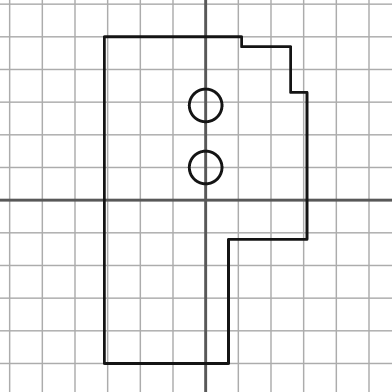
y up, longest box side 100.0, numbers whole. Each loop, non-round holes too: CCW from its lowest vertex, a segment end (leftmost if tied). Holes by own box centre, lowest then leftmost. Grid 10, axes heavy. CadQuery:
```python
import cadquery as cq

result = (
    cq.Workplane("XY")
    .moveTo(-31.0, -50.0)
    .lineTo(7.0, -50.0)
    .lineTo(7.0, -12.0)
    .lineTo(31.0, -12.0)
    .lineTo(31.0, 33.0)
    .lineTo(26.0, 33.0)
    .lineTo(26.0, 47.0)
    .lineTo(11.0, 47.0)
    .lineTo(11.0, 50.0)
    .lineTo(-31.0, 50.0)
    .close()
    .moveTo(0.0, 10.0)
    .circle(5.0)
    .moveTo(0.0, 29.0)
    .circle(5.0)
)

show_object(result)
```